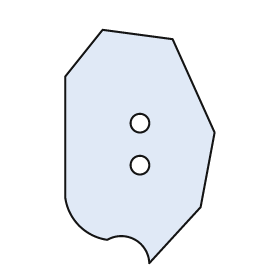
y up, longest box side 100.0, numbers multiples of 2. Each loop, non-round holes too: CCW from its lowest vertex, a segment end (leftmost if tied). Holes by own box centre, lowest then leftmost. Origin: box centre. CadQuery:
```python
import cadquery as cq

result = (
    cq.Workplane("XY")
    .moveTo(4.0, -50.0)
    .lineTo(26.0, -26.0)
    .lineTo(32.0, 6.0)
    .lineTo(14.0, 46.0)
    .lineTo(-16.0, 50.0)
    .lineTo(-32.0, 30.0)
    .lineTo(-32.0, -22.0)
    .threePointArc((-26.0, -34.0), (-14.0, -40.0))
    .threePointArc((-2.0, -40.0), (4.0, -50.0))
    .close()
    .moveTo(0.0, -8.0)
    .circle(4.0)
    .moveTo(0.0, 10.0)
    .circle(4.0)
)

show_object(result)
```